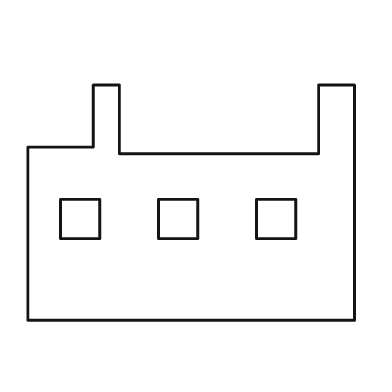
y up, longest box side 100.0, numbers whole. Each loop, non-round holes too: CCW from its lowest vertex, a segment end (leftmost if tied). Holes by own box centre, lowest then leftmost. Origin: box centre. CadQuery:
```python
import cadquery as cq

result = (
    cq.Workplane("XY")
    .moveTo(-50.0, -36.0)
    .lineTo(50.0, -36.0)
    .lineTo(50.0, 36.0)
    .lineTo(39.0, 36.0)
    .lineTo(39.0, 15.0)
    .lineTo(-22.0, 15.0)
    .lineTo(-22.0, 36.0)
    .lineTo(-30.0, 36.0)
    .lineTo(-30.0, 17.0)
    .lineTo(-50.0, 17.0)
    .close()
    .moveTo(-40.0, -11.0)
    .lineTo(-28.0, -11.0)
    .lineTo(-28.0, 1.0)
    .lineTo(-40.0, 1.0)
    .close()
    .moveTo(-10.0, -11.0)
    .lineTo(2.0, -11.0)
    .lineTo(2.0, 1.0)
    .lineTo(-10.0, 1.0)
    .close()
    .moveTo(20.0, -11.0)
    .lineTo(32.0, -11.0)
    .lineTo(32.0, 1.0)
    .lineTo(20.0, 1.0)
    .close()
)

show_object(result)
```